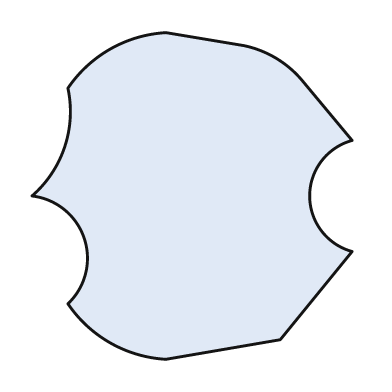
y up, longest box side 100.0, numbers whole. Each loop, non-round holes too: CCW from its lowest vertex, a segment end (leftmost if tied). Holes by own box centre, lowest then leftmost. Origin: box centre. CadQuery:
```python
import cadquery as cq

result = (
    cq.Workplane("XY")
    .moveTo(-8.0, -50.0)
    .lineTo(27.0, -44.0)
    .lineTo(49.0, -17.0)
    .threePointArc((36.0, 0.0), (49.0, 17.0))
    .lineTo(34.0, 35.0)
    .threePointArc((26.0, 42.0), (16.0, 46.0))
    .lineTo(-8.0, 50.0)
    .threePointArc((-25.0, 45.0), (-38.0, 33.0))
    .threePointArc((-39.0, 15.0), (-49.0, 0.0))
    .threePointArc((-33.0, -13.0), (-38.0, -33.0))
    .threePointArc((-25.0, -45.0), (-8.0, -50.0))
    .close()
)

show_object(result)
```